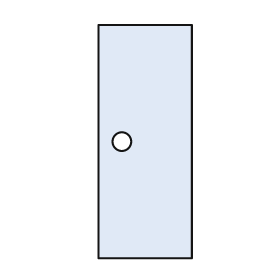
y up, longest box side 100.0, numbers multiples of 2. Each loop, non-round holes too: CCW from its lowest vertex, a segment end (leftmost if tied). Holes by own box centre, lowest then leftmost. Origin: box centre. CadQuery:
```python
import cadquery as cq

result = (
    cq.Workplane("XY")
    .moveTo(-20.0, -50.0)
    .lineTo(20.0, -50.0)
    .lineTo(20.0, 50.0)
    .lineTo(-20.0, 50.0)
    .close()
    .moveTo(-10.0, 0.0)
    .circle(4.0)
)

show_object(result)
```